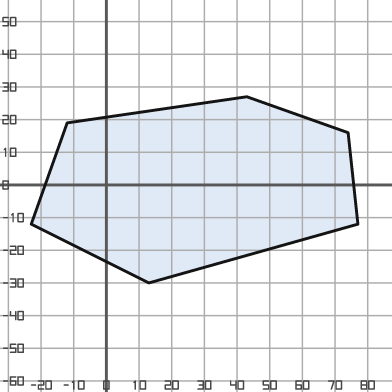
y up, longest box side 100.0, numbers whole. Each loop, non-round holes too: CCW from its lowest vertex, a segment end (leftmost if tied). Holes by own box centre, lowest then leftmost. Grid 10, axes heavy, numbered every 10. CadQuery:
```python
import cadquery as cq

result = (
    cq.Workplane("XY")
    .moveTo(13.0, -30.0)
    .lineTo(77.0, -12.0)
    .lineTo(74.0, 16.0)
    .lineTo(43.0, 27.0)
    .lineTo(-12.0, 19.0)
    .lineTo(-23.0, -12.0)
    .close()
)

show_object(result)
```